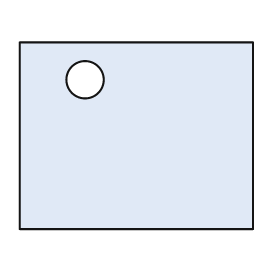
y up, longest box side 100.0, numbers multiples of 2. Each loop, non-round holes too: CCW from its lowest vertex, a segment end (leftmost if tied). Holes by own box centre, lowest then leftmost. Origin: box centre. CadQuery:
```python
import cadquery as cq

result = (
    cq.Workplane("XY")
    .moveTo(-50.0, -40.0)
    .lineTo(50.0, -40.0)
    .lineTo(50.0, 40.0)
    .lineTo(-50.0, 40.0)
    .close()
    .moveTo(-22.0, 24.0)
    .circle(8.0)
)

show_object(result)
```